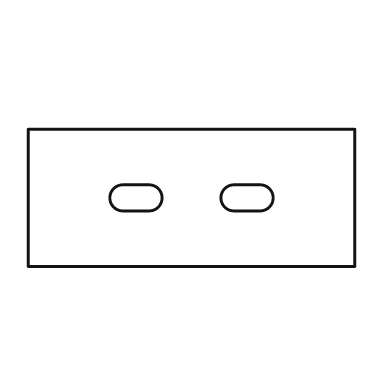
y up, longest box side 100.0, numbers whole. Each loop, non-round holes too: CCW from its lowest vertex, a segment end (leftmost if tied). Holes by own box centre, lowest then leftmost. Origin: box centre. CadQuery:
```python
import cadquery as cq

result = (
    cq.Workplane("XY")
    .moveTo(-50.0, -21.0)
    .lineTo(50.0, -21.0)
    .lineTo(50.0, 21.0)
    .lineTo(-50.0, 21.0)
    .close()
    .moveTo(-21.0, -4.0)
    .lineTo(-13.0, -4.0)
    .threePointArc((-9.0, 0.0), (-13.0, 4.0))
    .lineTo(-21.0, 4.0)
    .threePointArc((-25.0, 0.0), (-21.0, -4.0))
    .close()
    .moveTo(13.0, -4.0)
    .lineTo(21.0, -4.0)
    .threePointArc((25.0, 0.0), (21.0, 4.0))
    .lineTo(13.0, 4.0)
    .threePointArc((9.0, 0.0), (13.0, -4.0))
    .close()
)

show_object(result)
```